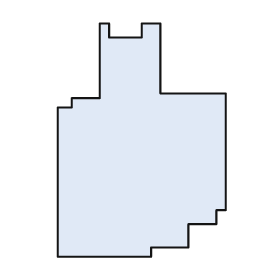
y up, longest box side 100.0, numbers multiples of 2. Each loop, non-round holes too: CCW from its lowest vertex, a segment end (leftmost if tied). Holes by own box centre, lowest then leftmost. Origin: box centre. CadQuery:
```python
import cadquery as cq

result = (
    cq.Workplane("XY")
    .moveTo(-36.0, -50.0)
    .lineTo(4.0, -50.0)
    .lineTo(4.0, -46.0)
    .lineTo(20.0, -46.0)
    .lineTo(20.0, -36.0)
    .lineTo(32.0, -36.0)
    .lineTo(32.0, -30.0)
    .lineTo(36.0, -30.0)
    .lineTo(36.0, 20.0)
    .lineTo(8.0, 20.0)
    .lineTo(8.0, 50.0)
    .lineTo(0.0, 50.0)
    .lineTo(0.0, 44.0)
    .lineTo(-14.0, 44.0)
    .lineTo(-14.0, 50.0)
    .lineTo(-18.0, 50.0)
    .lineTo(-18.0, 18.0)
    .lineTo(-30.0, 18.0)
    .lineTo(-30.0, 14.0)
    .lineTo(-36.0, 14.0)
    .close()
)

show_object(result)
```